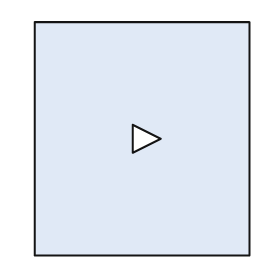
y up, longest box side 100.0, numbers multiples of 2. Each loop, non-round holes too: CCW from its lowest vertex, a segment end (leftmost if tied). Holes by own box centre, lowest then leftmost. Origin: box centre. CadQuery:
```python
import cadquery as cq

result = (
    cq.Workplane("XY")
    .moveTo(-46.0, -50.0)
    .lineTo(46.0, -50.0)
    .lineTo(46.0, 50.0)
    .lineTo(-46.0, 50.0)
    .close()
    .moveTo(-4.0, -6.0)
    .lineTo(8.0, 0.0)
    .lineTo(-4.0, 6.0)
    .close()
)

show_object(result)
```